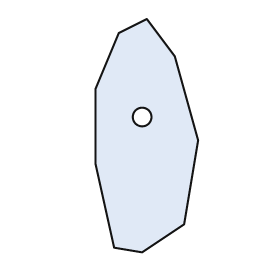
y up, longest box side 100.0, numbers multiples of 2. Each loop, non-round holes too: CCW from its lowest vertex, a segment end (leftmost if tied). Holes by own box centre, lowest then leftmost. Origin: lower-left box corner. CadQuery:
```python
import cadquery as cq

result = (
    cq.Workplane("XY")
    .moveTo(20.0, 0.0)
    .lineTo(38.0, 12.0)
    .lineTo(44.0, 48.0)
    .lineTo(34.0, 84.0)
    .lineTo(22.0, 100.0)
    .lineTo(10.0, 94.0)
    .lineTo(0.0, 70.0)
    .lineTo(0.0, 38.0)
    .lineTo(8.0, 2.0)
    .close()
    .moveTo(20.0, 58.0)
    .circle(4.0)
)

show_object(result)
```